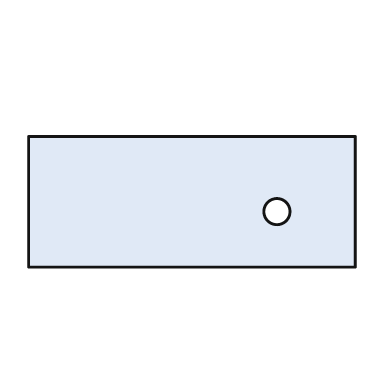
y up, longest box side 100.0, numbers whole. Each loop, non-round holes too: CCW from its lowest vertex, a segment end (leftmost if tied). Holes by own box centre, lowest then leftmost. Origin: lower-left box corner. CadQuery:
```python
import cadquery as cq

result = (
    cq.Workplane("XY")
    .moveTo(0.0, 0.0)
    .lineTo(100.0, 0.0)
    .lineTo(100.0, 40.0)
    .lineTo(0.0, 40.0)
    .close()
    .moveTo(76.0, 17.0)
    .circle(4.0)
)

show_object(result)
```